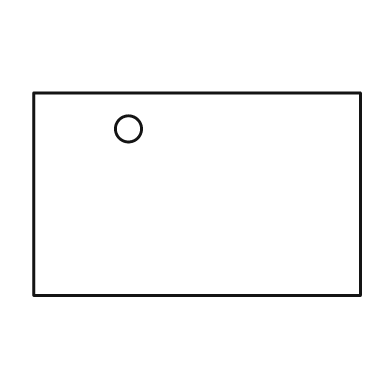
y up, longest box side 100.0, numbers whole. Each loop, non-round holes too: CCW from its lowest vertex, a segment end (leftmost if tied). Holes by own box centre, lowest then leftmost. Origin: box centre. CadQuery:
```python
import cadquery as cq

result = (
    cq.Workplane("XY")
    .moveTo(-50.0, -31.0)
    .lineTo(50.0, -31.0)
    .lineTo(50.0, 31.0)
    .lineTo(-50.0, 31.0)
    .close()
    .moveTo(-21.0, 20.0)
    .circle(4.0)
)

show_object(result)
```